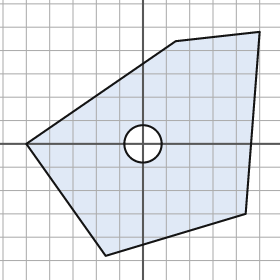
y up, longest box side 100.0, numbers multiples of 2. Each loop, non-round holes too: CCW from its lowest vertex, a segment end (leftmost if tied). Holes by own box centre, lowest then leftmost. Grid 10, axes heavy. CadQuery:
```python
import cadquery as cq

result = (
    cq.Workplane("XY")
    .moveTo(-16.0, -48.0)
    .lineTo(44.0, -30.0)
    .lineTo(50.0, 48.0)
    .lineTo(14.0, 44.0)
    .lineTo(-50.0, 0.0)
    .close()
    .moveTo(0.0, 0.0)
    .circle(8.0)
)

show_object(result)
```